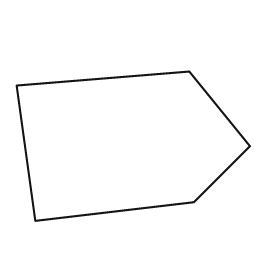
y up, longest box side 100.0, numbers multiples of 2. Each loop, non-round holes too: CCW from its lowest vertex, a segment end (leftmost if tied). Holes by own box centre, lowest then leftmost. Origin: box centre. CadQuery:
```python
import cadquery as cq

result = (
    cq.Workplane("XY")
    .moveTo(-42.0, -32.0)
    .lineTo(26.0, -24.0)
    .lineTo(50.0, 0.0)
    .lineTo(24.0, 32.0)
    .lineTo(-50.0, 26.0)
    .close()
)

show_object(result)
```